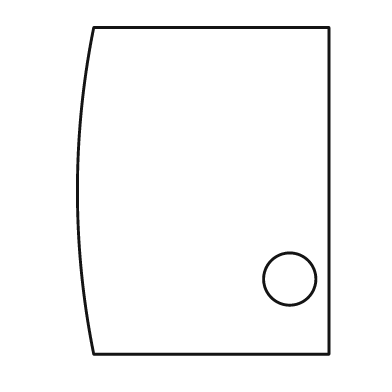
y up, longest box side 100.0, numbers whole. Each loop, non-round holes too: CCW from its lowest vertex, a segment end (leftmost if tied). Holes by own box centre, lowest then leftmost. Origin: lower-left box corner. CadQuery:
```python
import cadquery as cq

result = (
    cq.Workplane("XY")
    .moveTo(5.0, 0.0)
    .lineTo(77.0, 0.0)
    .lineTo(77.0, 100.0)
    .lineTo(5.0, 100.0)
    .threePointArc((0.0, 50.0), (5.0, 0.0))
    .close()
    .moveTo(65.0, 23.0)
    .circle(8.0)
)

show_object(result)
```